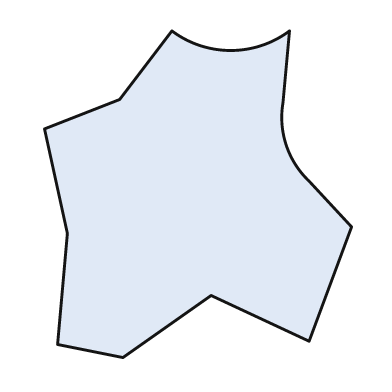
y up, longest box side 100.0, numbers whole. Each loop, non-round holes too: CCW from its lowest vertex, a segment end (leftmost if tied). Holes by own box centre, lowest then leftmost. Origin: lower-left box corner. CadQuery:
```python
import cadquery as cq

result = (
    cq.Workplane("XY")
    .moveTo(24.0, 0.0)
    .lineTo(51.0, 19.0)
    .lineTo(81.0, 5.0)
    .lineTo(94.0, 40.0)
    .lineTo(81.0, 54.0)
    .threePointArc((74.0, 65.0), (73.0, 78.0))
    .lineTo(75.0, 100.0)
    .threePointArc((57.0, 94.0), (39.0, 100.0))
    .lineTo(23.0, 79.0)
    .lineTo(0.0, 70.0)
    .lineTo(7.0, 38.0)
    .lineTo(4.0, 4.0)
    .close()
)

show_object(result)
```